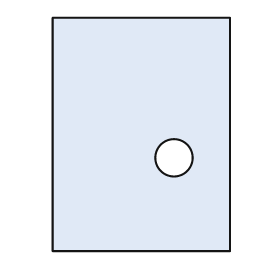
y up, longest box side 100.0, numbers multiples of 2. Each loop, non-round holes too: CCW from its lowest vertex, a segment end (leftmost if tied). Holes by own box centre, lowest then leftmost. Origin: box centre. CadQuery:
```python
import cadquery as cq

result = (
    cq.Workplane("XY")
    .moveTo(-38.0, -50.0)
    .lineTo(38.0, -50.0)
    .lineTo(38.0, 50.0)
    .lineTo(-38.0, 50.0)
    .close()
    .moveTo(14.0, -10.0)
    .circle(8.0)
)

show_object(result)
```